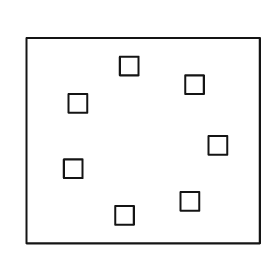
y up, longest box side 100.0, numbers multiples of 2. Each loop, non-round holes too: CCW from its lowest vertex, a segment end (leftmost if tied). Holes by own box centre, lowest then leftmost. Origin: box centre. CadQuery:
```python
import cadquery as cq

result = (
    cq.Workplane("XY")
    .moveTo(-50.0, -44.0)
    .lineTo(50.0, -44.0)
    .lineTo(50.0, 44.0)
    .lineTo(-50.0, 44.0)
    .close()
    .moveTo(-12.0, -36.0)
    .lineTo(-4.0, -36.0)
    .lineTo(-4.0, -28.0)
    .lineTo(-12.0, -28.0)
    .close()
    .moveTo(16.0, -30.0)
    .lineTo(24.0, -30.0)
    .lineTo(24.0, -22.0)
    .lineTo(16.0, -22.0)
    .close()
    .moveTo(-34.0, -16.0)
    .lineTo(-26.0, -16.0)
    .lineTo(-26.0, -8.0)
    .lineTo(-34.0, -8.0)
    .close()
    .moveTo(28.0, -6.0)
    .lineTo(36.0, -6.0)
    .lineTo(36.0, 2.0)
    .lineTo(28.0, 2.0)
    .close()
    .moveTo(-32.0, 12.0)
    .lineTo(-24.0, 12.0)
    .lineTo(-24.0, 20.0)
    .lineTo(-32.0, 20.0)
    .close()
    .moveTo(18.0, 20.0)
    .lineTo(26.0, 20.0)
    .lineTo(26.0, 28.0)
    .lineTo(18.0, 28.0)
    .close()
    .moveTo(-10.0, 28.0)
    .lineTo(-2.0, 28.0)
    .lineTo(-2.0, 36.0)
    .lineTo(-10.0, 36.0)
    .close()
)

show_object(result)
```